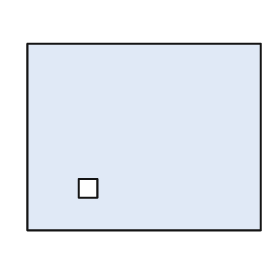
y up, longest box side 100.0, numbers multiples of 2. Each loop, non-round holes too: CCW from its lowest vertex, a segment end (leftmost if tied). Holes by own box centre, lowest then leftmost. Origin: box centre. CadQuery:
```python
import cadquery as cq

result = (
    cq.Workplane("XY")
    .moveTo(-50.0, -40.0)
    .lineTo(50.0, -40.0)
    .lineTo(50.0, 40.0)
    .lineTo(-50.0, 40.0)
    .close()
    .moveTo(-28.0, -26.0)
    .lineTo(-20.0, -26.0)
    .lineTo(-20.0, -18.0)
    .lineTo(-28.0, -18.0)
    .close()
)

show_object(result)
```